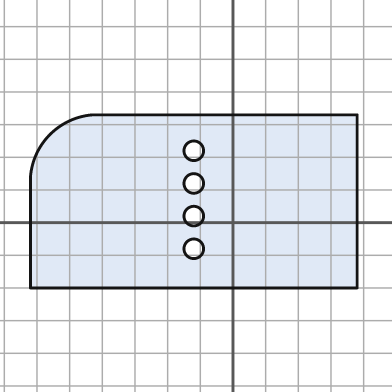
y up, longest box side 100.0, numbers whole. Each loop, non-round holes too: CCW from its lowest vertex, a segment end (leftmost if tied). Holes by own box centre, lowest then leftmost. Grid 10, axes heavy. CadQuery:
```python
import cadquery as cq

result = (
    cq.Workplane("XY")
    .moveTo(-62.0, -20.0)
    .lineTo(38.0, -20.0)
    .lineTo(38.0, 33.0)
    .lineTo(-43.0, 33.0)
    .threePointArc((-56.0, 27.0), (-62.0, 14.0))
    .close()
    .moveTo(-12.0, -8.0)
    .circle(3.0)
    .moveTo(-12.0, 2.0)
    .circle(3.0)
    .moveTo(-12.0, 12.0)
    .circle(3.0)
    .moveTo(-12.0, 22.0)
    .circle(3.0)
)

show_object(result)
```